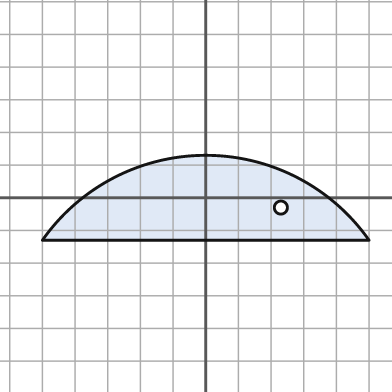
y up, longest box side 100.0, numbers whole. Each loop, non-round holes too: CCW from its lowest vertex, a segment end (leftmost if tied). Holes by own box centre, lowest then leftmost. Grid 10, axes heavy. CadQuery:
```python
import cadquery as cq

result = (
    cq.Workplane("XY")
    .moveTo(-50.0, -13.0)
    .lineTo(50.0, -13.0)
    .threePointArc((0.0, 13.0), (-50.0, -13.0))
    .close()
    .moveTo(23.0, -3.0)
    .circle(2.0)
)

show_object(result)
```